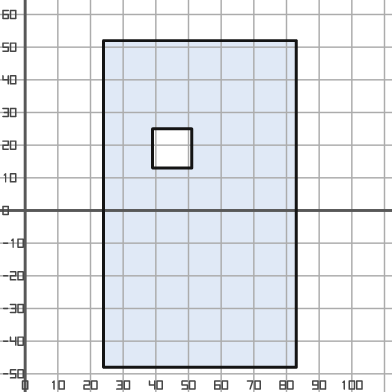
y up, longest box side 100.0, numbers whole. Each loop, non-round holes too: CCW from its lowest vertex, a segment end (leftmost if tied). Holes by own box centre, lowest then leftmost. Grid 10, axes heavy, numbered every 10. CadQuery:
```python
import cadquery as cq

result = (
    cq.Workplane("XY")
    .moveTo(24.0, -48.0)
    .lineTo(83.0, -48.0)
    .lineTo(83.0, 52.0)
    .lineTo(24.0, 52.0)
    .close()
    .moveTo(39.0, 13.0)
    .lineTo(51.0, 13.0)
    .lineTo(51.0, 25.0)
    .lineTo(39.0, 25.0)
    .close()
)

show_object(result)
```